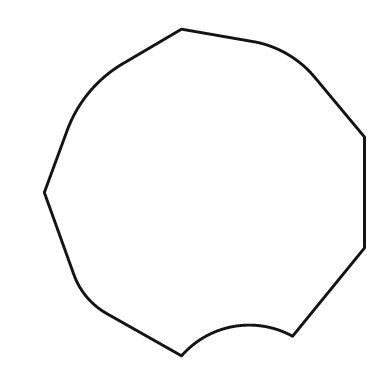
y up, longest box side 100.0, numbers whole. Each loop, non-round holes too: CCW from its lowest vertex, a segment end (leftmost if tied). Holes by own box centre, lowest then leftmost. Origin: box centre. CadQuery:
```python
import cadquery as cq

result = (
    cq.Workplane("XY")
    .moveTo(-7.0, -50.0)
    .threePointArc((9.0, -41.0), (27.0, -44.0))
    .lineTo(49.0, -17.0)
    .lineTo(49.0, 17.0)
    .lineTo(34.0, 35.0)
    .threePointArc((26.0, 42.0), (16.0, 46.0))
    .lineTo(-7.0, 50.0)
    .lineTo(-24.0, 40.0)
    .threePointArc((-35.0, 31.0), (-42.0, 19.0))
    .lineTo(-49.0, 0.0)
    .lineTo(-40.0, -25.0)
    .threePointArc((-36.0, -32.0), (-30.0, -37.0))
    .close()
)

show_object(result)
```